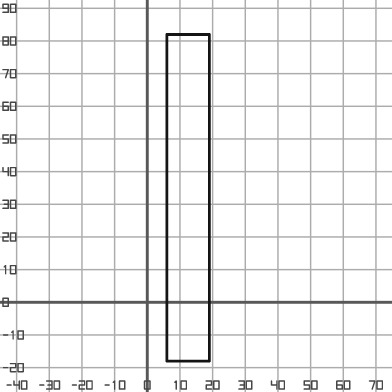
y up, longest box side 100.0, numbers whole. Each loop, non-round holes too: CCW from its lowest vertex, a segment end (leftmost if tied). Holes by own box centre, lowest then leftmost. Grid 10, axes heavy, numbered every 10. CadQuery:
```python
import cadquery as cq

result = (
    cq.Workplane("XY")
    .moveTo(6.0, -18.0)
    .lineTo(19.0, -18.0)
    .lineTo(19.0, 82.0)
    .lineTo(6.0, 82.0)
    .close()
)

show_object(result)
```